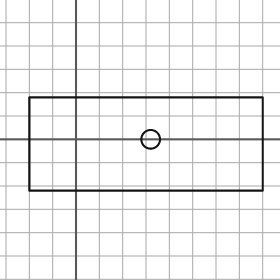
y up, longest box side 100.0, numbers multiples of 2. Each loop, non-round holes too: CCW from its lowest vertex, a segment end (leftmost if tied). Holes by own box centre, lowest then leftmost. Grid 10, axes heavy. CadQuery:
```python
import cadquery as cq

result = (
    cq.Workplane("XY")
    .moveTo(-20.0, -22.0)
    .lineTo(80.0, -22.0)
    .lineTo(80.0, 18.0)
    .lineTo(-20.0, 18.0)
    .close()
    .moveTo(32.0, 0.0)
    .circle(4.0)
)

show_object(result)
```